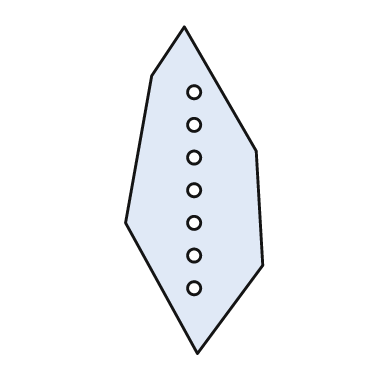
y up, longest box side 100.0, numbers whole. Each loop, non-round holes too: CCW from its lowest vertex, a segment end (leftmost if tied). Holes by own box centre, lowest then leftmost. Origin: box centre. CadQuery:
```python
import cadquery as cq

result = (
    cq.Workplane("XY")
    .moveTo(1.0, -50.0)
    .lineTo(21.0, -23.0)
    .lineTo(19.0, 12.0)
    .lineTo(-3.0, 50.0)
    .lineTo(-13.0, 35.0)
    .lineTo(-21.0, -10.0)
    .close()
    .moveTo(0.0, -30.0)
    .circle(2.0)
    .moveTo(0.0, -20.0)
    .circle(2.0)
    .moveTo(0.0, -10.0)
    .circle(2.0)
    .moveTo(0.0, 0.0)
    .circle(2.0)
    .moveTo(0.0, 10.0)
    .circle(2.0)
    .moveTo(0.0, 20.0)
    .circle(2.0)
    .moveTo(0.0, 30.0)
    .circle(2.0)
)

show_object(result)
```